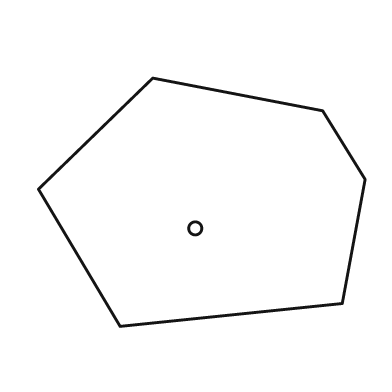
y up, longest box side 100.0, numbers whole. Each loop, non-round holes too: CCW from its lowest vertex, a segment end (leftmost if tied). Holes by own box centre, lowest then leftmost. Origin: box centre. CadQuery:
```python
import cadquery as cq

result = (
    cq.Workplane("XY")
    .moveTo(-25.0, -38.0)
    .lineTo(43.0, -31.0)
    .lineTo(50.0, 7.0)
    .lineTo(37.0, 28.0)
    .lineTo(-15.0, 38.0)
    .lineTo(-50.0, 4.0)
    .close()
    .moveTo(-2.0, -8.0)
    .circle(2.0)
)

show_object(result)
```